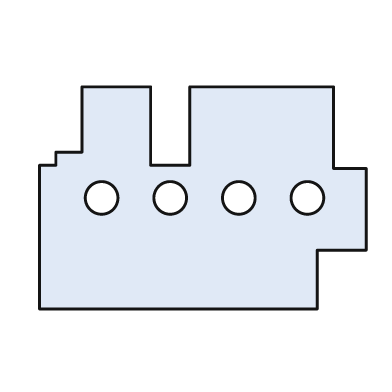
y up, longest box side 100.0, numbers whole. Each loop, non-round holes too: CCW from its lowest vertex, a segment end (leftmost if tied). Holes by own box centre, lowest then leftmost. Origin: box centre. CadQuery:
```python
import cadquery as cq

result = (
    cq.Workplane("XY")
    .moveTo(-50.0, -34.0)
    .lineTo(35.0, -34.0)
    .lineTo(35.0, -16.0)
    .lineTo(50.0, -16.0)
    .lineTo(50.0, 9.0)
    .lineTo(40.0, 9.0)
    .lineTo(40.0, 34.0)
    .lineTo(-4.0, 34.0)
    .lineTo(-4.0, 10.0)
    .lineTo(-16.0, 10.0)
    .lineTo(-16.0, 34.0)
    .lineTo(-37.0, 34.0)
    .lineTo(-37.0, 14.0)
    .lineTo(-45.0, 14.0)
    .lineTo(-45.0, 10.0)
    .lineTo(-50.0, 10.0)
    .close()
    .moveTo(-31.0, 0.0)
    .circle(5.0)
    .moveTo(-10.0, 0.0)
    .circle(5.0)
    .moveTo(11.0, 0.0)
    .circle(5.0)
    .moveTo(32.0, 0.0)
    .circle(5.0)
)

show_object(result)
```